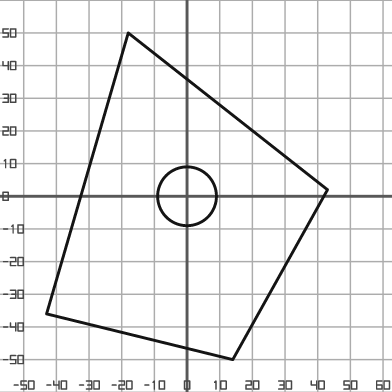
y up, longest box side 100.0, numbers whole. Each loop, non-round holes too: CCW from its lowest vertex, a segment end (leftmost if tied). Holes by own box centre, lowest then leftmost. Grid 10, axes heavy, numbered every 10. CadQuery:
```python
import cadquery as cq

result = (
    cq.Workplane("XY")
    .moveTo(14.0, -50.0)
    .lineTo(43.0, 2.0)
    .lineTo(-18.0, 50.0)
    .lineTo(-43.0, -36.0)
    .close()
    .moveTo(0.0, 0.0)
    .circle(9.0)
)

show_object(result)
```